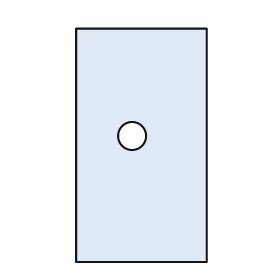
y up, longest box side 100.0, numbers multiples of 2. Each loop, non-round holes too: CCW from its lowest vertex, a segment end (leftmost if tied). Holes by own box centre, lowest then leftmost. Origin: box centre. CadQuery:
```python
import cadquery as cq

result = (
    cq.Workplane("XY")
    .moveTo(-28.0, -50.0)
    .lineTo(28.0, -50.0)
    .lineTo(28.0, 50.0)
    .lineTo(-28.0, 50.0)
    .close()
    .moveTo(-4.0, 4.0)
    .circle(6.0)
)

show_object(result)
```